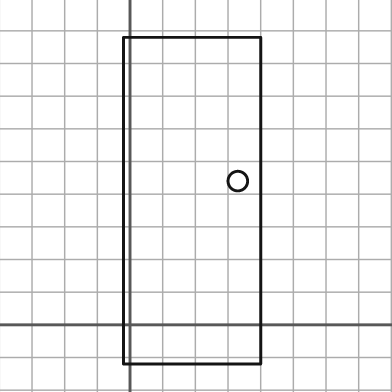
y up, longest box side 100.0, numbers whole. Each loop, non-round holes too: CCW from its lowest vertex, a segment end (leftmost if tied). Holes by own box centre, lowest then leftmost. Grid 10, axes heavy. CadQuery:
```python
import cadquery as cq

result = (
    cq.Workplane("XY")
    .moveTo(-2.0, -12.0)
    .lineTo(40.0, -12.0)
    .lineTo(40.0, 88.0)
    .lineTo(-2.0, 88.0)
    .close()
    .moveTo(33.0, 44.0)
    .circle(3.0)
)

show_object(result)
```